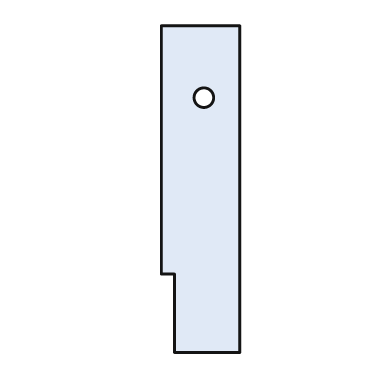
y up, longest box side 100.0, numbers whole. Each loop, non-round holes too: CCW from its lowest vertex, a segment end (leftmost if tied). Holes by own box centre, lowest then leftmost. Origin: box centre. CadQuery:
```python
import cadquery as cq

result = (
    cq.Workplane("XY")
    .moveTo(-8.0, -50.0)
    .lineTo(12.0, -50.0)
    .lineTo(12.0, 50.0)
    .lineTo(-12.0, 50.0)
    .lineTo(-12.0, -26.0)
    .lineTo(-8.0, -26.0)
    .close()
    .moveTo(1.0, 28.0)
    .circle(3.0)
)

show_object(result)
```